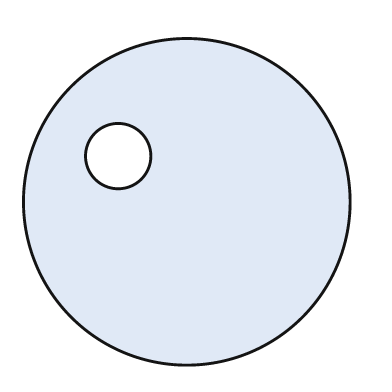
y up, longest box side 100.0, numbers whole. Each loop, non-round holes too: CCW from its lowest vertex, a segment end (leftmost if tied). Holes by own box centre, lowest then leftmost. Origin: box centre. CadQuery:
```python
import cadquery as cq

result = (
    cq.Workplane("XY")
    .moveTo(0.0, 0.0)
    .circle(50.0)
    .moveTo(-21.0, 14.0)
    .circle(10.0)
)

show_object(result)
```